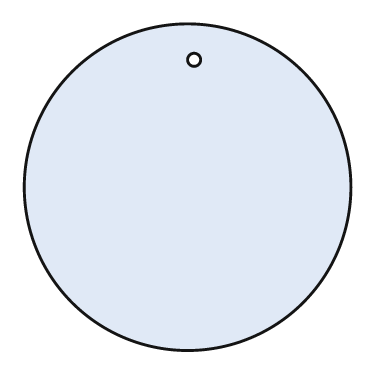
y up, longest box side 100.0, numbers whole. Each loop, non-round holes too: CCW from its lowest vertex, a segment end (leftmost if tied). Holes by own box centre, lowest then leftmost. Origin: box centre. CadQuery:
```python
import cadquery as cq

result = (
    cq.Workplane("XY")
    .moveTo(0.0, 0.0)
    .circle(50.0)
    .moveTo(2.0, 39.0)
    .circle(2.0)
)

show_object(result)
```